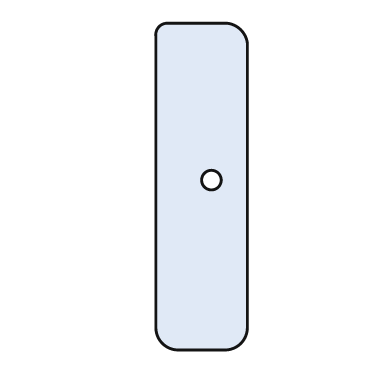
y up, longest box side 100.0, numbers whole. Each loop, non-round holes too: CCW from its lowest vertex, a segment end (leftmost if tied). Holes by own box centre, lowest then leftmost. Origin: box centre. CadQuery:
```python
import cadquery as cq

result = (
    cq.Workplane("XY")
    .moveTo(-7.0, -50.0)
    .lineTo(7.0, -50.0)
    .threePointArc((12.0, -48.0), (14.0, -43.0))
    .lineTo(14.0, 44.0)
    .threePointArc((12.0, 48.0), (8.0, 50.0))
    .lineTo(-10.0, 50.0)
    .threePointArc((-13.0, 49.0), (-14.0, 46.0))
    .lineTo(-14.0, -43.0)
    .threePointArc((-12.0, -48.0), (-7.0, -50.0))
    .close()
    .moveTo(3.0, 2.0)
    .circle(3.0)
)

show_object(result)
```